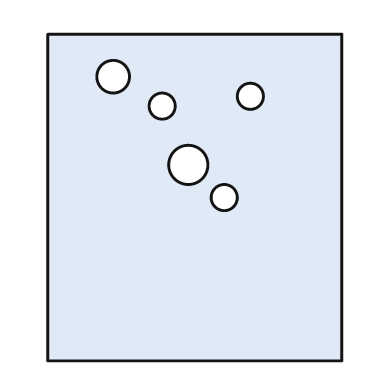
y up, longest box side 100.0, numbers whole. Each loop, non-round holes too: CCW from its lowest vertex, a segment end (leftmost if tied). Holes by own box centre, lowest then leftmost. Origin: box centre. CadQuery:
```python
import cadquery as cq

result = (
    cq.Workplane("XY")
    .moveTo(-45.0, -50.0)
    .lineTo(45.0, -50.0)
    .lineTo(45.0, 50.0)
    .lineTo(-45.0, 50.0)
    .close()
    .moveTo(9.0, 0.0)
    .circle(4.0)
    .moveTo(-2.0, 10.0)
    .circle(6.0)
    .moveTo(-10.0, 28.0)
    .circle(4.0)
    .moveTo(17.0, 31.0)
    .circle(4.0)
    .moveTo(-25.0, 37.0)
    .circle(5.0)
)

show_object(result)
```